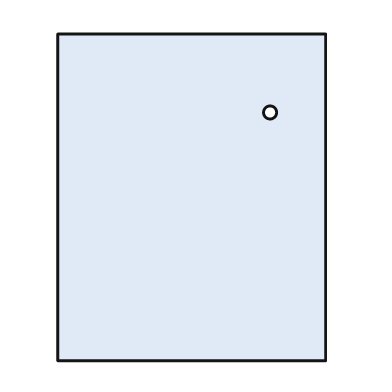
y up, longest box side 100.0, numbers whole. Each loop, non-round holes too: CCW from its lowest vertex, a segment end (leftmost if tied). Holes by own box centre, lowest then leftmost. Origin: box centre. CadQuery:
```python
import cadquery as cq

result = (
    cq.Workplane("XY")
    .moveTo(-41.0, -50.0)
    .lineTo(41.0, -50.0)
    .lineTo(41.0, 50.0)
    .lineTo(-41.0, 50.0)
    .close()
    .moveTo(24.0, 26.0)
    .circle(2.0)
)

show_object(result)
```